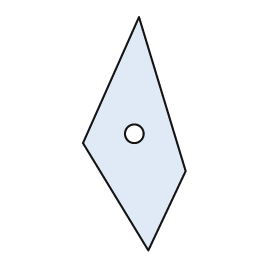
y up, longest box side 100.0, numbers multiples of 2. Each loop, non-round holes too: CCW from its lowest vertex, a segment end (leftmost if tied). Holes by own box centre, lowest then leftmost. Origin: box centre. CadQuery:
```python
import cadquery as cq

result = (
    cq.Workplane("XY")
    .moveTo(6.0, -50.0)
    .lineTo(22.0, -16.0)
    .lineTo(2.0, 50.0)
    .lineTo(-22.0, -4.0)
    .close()
    .moveTo(0.0, 0.0)
    .circle(4.0)
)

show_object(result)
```